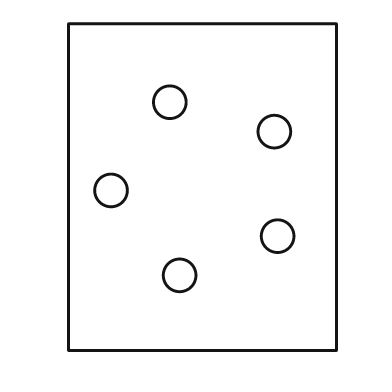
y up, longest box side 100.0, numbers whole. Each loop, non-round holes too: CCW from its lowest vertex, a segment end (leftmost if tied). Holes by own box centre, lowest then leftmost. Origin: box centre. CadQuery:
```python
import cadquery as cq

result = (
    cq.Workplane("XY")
    .moveTo(-41.0, -50.0)
    .lineTo(41.0, -50.0)
    .lineTo(41.0, 50.0)
    .lineTo(-41.0, 50.0)
    .close()
    .moveTo(-7.0, -27.0)
    .circle(5.0)
    .moveTo(23.0, -15.0)
    .circle(5.0)
    .moveTo(-28.0, -1.0)
    .circle(5.0)
    .moveTo(22.0, 17.0)
    .circle(5.0)
    .moveTo(-10.0, 26.0)
    .circle(5.0)
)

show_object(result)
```